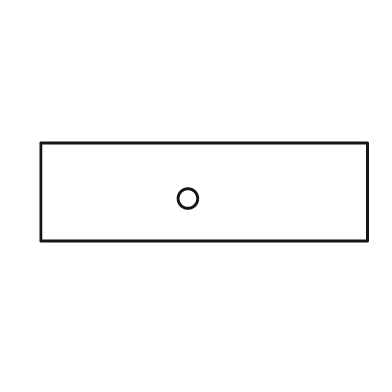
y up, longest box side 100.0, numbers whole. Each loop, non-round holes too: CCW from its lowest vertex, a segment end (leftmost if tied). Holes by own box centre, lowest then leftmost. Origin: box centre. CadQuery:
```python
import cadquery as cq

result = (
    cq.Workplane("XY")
    .moveTo(-50.0, -15.0)
    .lineTo(50.0, -15.0)
    .lineTo(50.0, 15.0)
    .lineTo(-50.0, 15.0)
    .close()
    .moveTo(-5.0, -2.0)
    .circle(3.0)
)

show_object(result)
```